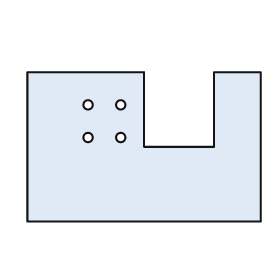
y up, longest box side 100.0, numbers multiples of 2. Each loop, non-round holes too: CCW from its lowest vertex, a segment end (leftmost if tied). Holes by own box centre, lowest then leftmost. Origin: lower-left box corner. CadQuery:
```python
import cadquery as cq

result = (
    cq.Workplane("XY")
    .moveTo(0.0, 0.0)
    .lineTo(100.0, 0.0)
    .lineTo(100.0, 64.0)
    .lineTo(80.0, 64.0)
    .lineTo(80.0, 32.0)
    .lineTo(50.0, 32.0)
    .lineTo(50.0, 64.0)
    .lineTo(0.0, 64.0)
    .close()
    .moveTo(26.0, 36.0)
    .circle(2.0)
    .moveTo(40.0, 36.0)
    .circle(2.0)
    .moveTo(26.0, 50.0)
    .circle(2.0)
    .moveTo(40.0, 50.0)
    .circle(2.0)
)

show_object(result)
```